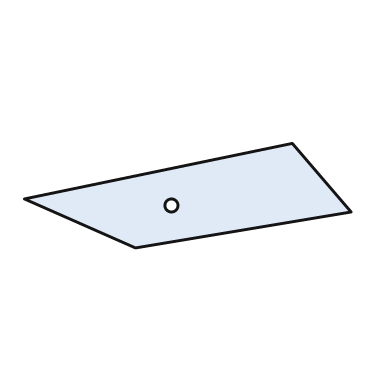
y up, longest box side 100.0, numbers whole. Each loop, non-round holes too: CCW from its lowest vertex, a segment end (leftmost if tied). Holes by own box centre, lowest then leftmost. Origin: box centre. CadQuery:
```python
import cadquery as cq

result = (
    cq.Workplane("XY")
    .moveTo(-16.0, -16.0)
    .lineTo(50.0, -5.0)
    .lineTo(32.0, 16.0)
    .lineTo(-50.0, -1.0)
    .close()
    .moveTo(-5.0, -3.0)
    .circle(2.0)
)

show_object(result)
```